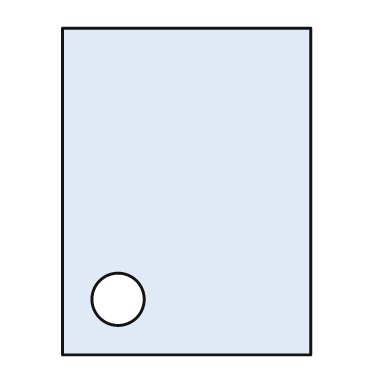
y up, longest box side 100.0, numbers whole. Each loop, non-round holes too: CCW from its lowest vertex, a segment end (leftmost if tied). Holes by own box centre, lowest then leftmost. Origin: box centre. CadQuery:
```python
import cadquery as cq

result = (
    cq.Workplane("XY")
    .moveTo(-38.0, -50.0)
    .lineTo(38.0, -50.0)
    .lineTo(38.0, 50.0)
    .lineTo(-38.0, 50.0)
    .close()
    .moveTo(-21.0, -33.0)
    .circle(8.0)
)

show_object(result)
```